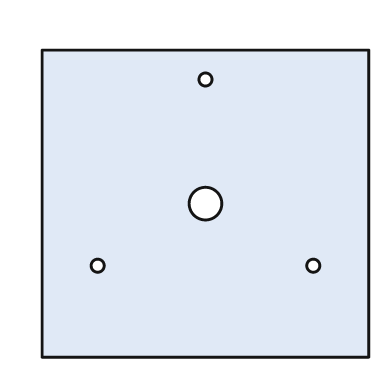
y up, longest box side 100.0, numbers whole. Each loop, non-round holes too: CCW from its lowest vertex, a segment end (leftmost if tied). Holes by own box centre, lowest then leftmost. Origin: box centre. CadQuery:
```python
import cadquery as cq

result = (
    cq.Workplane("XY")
    .moveTo(-50.0, -47.0)
    .lineTo(50.0, -47.0)
    .lineTo(50.0, 47.0)
    .lineTo(-50.0, 47.0)
    .close()
    .moveTo(-33.0, -19.0)
    .circle(2.0)
    .moveTo(33.0, -19.0)
    .circle(2.0)
    .moveTo(0.0, 0.0)
    .circle(5.0)
    .moveTo(0.0, 38.0)
    .circle(2.0)
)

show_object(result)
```